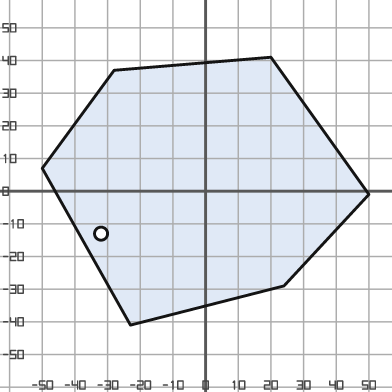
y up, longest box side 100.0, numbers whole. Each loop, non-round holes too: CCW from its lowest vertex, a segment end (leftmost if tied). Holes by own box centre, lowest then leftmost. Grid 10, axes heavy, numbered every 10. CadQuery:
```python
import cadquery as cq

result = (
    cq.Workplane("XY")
    .moveTo(-23.0, -41.0)
    .lineTo(24.0, -29.0)
    .lineTo(50.0, -1.0)
    .lineTo(20.0, 41.0)
    .lineTo(-28.0, 37.0)
    .lineTo(-50.0, 7.0)
    .close()
    .moveTo(-32.0, -13.0)
    .circle(2.0)
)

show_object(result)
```